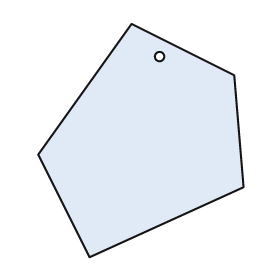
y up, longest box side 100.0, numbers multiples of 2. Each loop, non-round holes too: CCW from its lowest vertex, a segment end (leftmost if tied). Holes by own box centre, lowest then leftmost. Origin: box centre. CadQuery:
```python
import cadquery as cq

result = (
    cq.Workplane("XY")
    .moveTo(-22.0, -50.0)
    .lineTo(44.0, -20.0)
    .lineTo(40.0, 28.0)
    .lineTo(-4.0, 50.0)
    .lineTo(-44.0, -6.0)
    .close()
    .moveTo(8.0, 36.0)
    .circle(2.0)
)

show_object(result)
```